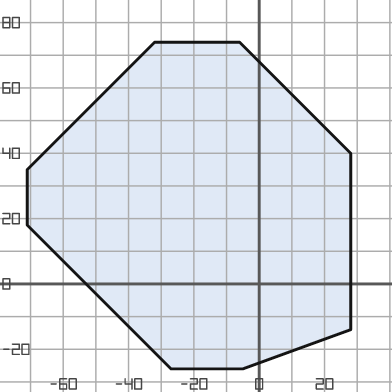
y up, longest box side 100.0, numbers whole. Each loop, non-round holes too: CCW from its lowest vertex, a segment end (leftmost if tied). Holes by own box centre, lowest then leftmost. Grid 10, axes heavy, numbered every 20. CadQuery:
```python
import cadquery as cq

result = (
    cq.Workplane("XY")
    .moveTo(-27.0, -26.0)
    .lineTo(-5.0, -26.0)
    .lineTo(28.0, -14.0)
    .lineTo(28.0, 40.0)
    .lineTo(-6.0, 74.0)
    .lineTo(-32.0, 74.0)
    .lineTo(-71.0, 35.0)
    .lineTo(-71.0, 18.0)
    .close()
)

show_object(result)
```